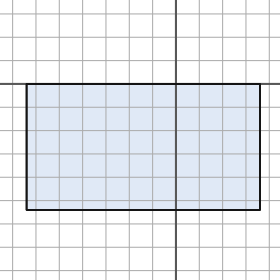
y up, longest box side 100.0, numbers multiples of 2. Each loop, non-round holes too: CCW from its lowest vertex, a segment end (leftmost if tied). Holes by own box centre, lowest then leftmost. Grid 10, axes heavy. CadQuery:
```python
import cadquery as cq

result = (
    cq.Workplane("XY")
    .moveTo(-64.0, -54.0)
    .lineTo(36.0, -54.0)
    .lineTo(36.0, 0.0)
    .lineTo(-64.0, 0.0)
    .close()
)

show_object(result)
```